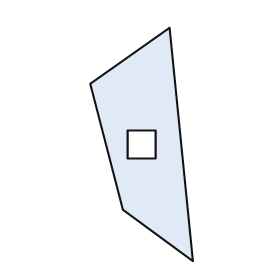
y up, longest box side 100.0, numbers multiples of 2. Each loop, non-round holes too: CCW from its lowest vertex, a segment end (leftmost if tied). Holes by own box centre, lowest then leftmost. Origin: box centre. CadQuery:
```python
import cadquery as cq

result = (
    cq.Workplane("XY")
    .moveTo(22.0, -50.0)
    .lineTo(12.0, 50.0)
    .lineTo(-22.0, 26.0)
    .lineTo(-8.0, -28.0)
    .close()
    .moveTo(-6.0, -6.0)
    .lineTo(6.0, -6.0)
    .lineTo(6.0, 6.0)
    .lineTo(-6.0, 6.0)
    .close()
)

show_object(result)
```